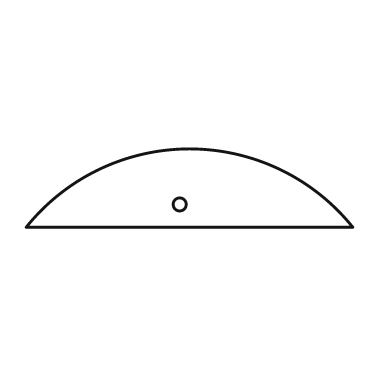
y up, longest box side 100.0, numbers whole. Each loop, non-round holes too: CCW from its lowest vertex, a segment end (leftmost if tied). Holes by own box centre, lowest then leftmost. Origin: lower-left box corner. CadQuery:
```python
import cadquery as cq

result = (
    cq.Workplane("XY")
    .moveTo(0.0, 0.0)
    .lineTo(100.0, 0.0)
    .threePointArc((50.0, 24.0), (0.0, 0.0))
    .close()
    .moveTo(47.0, 7.0)
    .circle(2.0)
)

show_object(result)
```